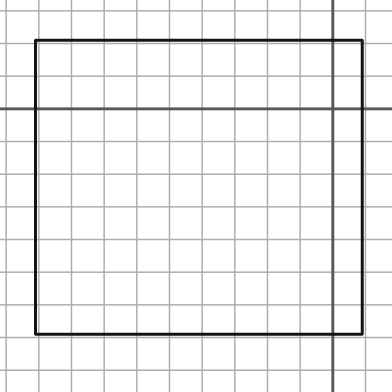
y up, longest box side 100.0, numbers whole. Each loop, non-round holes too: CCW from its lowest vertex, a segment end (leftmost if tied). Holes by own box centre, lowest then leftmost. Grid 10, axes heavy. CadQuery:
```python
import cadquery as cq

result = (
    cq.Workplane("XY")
    .moveTo(-91.0, -69.0)
    .lineTo(9.0, -69.0)
    .lineTo(9.0, 21.0)
    .lineTo(-91.0, 21.0)
    .close()
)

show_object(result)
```